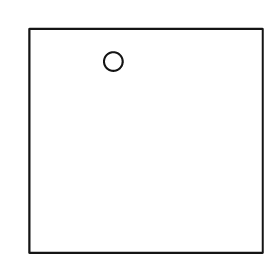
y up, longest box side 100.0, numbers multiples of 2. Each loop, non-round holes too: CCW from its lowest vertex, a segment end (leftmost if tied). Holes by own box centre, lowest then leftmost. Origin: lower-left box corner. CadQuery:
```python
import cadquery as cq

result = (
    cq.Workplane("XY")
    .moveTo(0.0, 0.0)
    .lineTo(100.0, 0.0)
    .lineTo(100.0, 96.0)
    .lineTo(0.0, 96.0)
    .close()
    .moveTo(36.0, 82.0)
    .circle(4.0)
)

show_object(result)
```